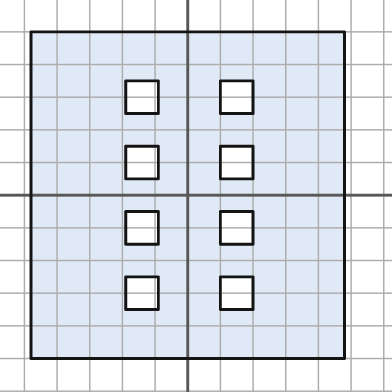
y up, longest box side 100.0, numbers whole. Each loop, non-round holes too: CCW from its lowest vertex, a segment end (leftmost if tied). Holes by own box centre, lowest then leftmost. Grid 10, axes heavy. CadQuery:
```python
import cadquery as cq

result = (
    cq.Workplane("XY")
    .moveTo(-48.0, -50.0)
    .lineTo(48.0, -50.0)
    .lineTo(48.0, 50.0)
    .lineTo(-48.0, 50.0)
    .close()
    .moveTo(-19.0, -35.0)
    .lineTo(-9.0, -35.0)
    .lineTo(-9.0, -25.0)
    .lineTo(-19.0, -25.0)
    .close()
    .moveTo(10.0, -35.0)
    .lineTo(20.0, -35.0)
    .lineTo(20.0, -25.0)
    .lineTo(10.0, -25.0)
    .close()
    .moveTo(-19.0, -15.0)
    .lineTo(-9.0, -15.0)
    .lineTo(-9.0, -5.0)
    .lineTo(-19.0, -5.0)
    .close()
    .moveTo(10.0, -15.0)
    .lineTo(20.0, -15.0)
    .lineTo(20.0, -5.0)
    .lineTo(10.0, -5.0)
    .close()
    .moveTo(-19.0, 5.0)
    .lineTo(-9.0, 5.0)
    .lineTo(-9.0, 15.0)
    .lineTo(-19.0, 15.0)
    .close()
    .moveTo(10.0, 5.0)
    .lineTo(20.0, 5.0)
    .lineTo(20.0, 15.0)
    .lineTo(10.0, 15.0)
    .close()
    .moveTo(-19.0, 25.0)
    .lineTo(-9.0, 25.0)
    .lineTo(-9.0, 35.0)
    .lineTo(-19.0, 35.0)
    .close()
    .moveTo(10.0, 25.0)
    .lineTo(20.0, 25.0)
    .lineTo(20.0, 35.0)
    .lineTo(10.0, 35.0)
    .close()
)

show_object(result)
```